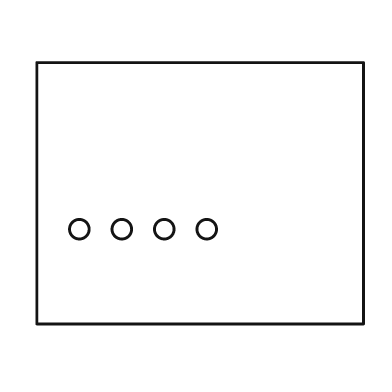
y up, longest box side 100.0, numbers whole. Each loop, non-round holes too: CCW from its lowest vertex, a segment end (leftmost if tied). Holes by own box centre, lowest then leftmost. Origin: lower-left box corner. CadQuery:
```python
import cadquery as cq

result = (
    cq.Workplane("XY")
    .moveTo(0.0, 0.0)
    .lineTo(100.0, 0.0)
    .lineTo(100.0, 80.0)
    .lineTo(0.0, 80.0)
    .close()
    .moveTo(13.0, 29.0)
    .circle(3.0)
    .moveTo(26.0, 29.0)
    .circle(3.0)
    .moveTo(39.0, 29.0)
    .circle(3.0)
    .moveTo(52.0, 29.0)
    .circle(3.0)
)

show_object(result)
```